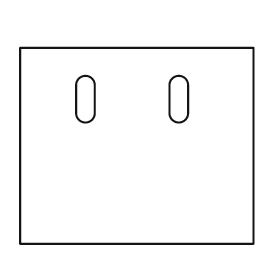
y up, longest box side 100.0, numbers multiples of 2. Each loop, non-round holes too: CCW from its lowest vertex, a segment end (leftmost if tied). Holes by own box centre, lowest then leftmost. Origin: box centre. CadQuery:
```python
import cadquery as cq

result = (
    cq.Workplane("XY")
    .moveTo(-50.0, -42.0)
    .lineTo(50.0, -42.0)
    .lineTo(50.0, 42.0)
    .lineTo(-50.0, 42.0)
    .close()
    .moveTo(-26.0, 14.0)
    .threePointArc((-22.0, 10.0), (-18.0, 14.0))
    .lineTo(-18.0, 26.0)
    .threePointArc((-22.0, 30.0), (-26.0, 26.0))
    .close()
    .moveTo(14.0, 14.0)
    .threePointArc((18.0, 10.0), (22.0, 14.0))
    .lineTo(22.0, 26.0)
    .threePointArc((18.0, 30.0), (14.0, 26.0))
    .close()
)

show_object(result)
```